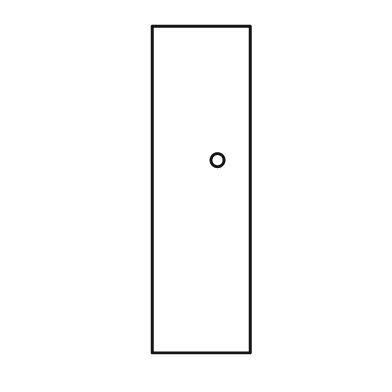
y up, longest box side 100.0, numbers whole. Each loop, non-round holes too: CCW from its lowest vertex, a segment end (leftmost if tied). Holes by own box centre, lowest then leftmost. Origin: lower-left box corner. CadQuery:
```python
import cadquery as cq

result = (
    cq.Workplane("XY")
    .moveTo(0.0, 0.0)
    .lineTo(30.0, 0.0)
    .lineTo(30.0, 100.0)
    .lineTo(0.0, 100.0)
    .close()
    .moveTo(20.0, 59.0)
    .circle(2.0)
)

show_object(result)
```